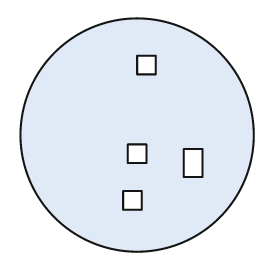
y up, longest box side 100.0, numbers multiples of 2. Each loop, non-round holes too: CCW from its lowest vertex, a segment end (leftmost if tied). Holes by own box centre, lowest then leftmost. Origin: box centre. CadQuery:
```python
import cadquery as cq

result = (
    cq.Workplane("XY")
    .moveTo(0.0, 0.0)
    .circle(50.0)
    .moveTo(-6.0, -32.0)
    .lineTo(2.0, -32.0)
    .lineTo(2.0, -24.0)
    .lineTo(-6.0, -24.0)
    .close()
    .moveTo(20.0, -18.0)
    .lineTo(28.0, -18.0)
    .lineTo(28.0, -6.0)
    .lineTo(20.0, -6.0)
    .close()
    .moveTo(-4.0, -12.0)
    .lineTo(4.0, -12.0)
    .lineTo(4.0, -4.0)
    .lineTo(-4.0, -4.0)
    .close()
    .moveTo(0.0, 26.0)
    .lineTo(8.0, 26.0)
    .lineTo(8.0, 34.0)
    .lineTo(0.0, 34.0)
    .close()
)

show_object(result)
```